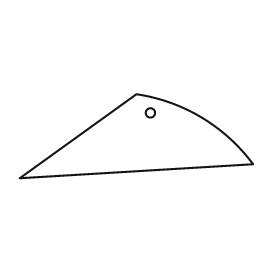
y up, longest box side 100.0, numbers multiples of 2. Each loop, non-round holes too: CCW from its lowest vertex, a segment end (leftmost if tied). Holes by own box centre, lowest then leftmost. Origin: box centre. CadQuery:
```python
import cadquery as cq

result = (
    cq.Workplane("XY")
    .moveTo(-50.0, -18.0)
    .lineTo(50.0, -12.0)
    .threePointArc((28.0, 8.0), (0.0, 18.0))
    .close()
    .moveTo(6.0, 10.0)
    .circle(2.0)
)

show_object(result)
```